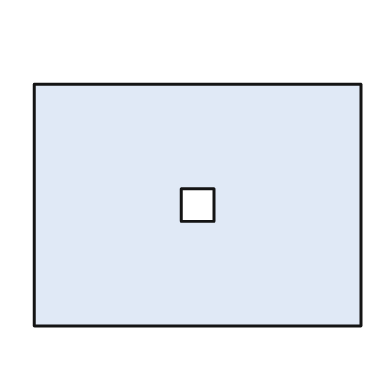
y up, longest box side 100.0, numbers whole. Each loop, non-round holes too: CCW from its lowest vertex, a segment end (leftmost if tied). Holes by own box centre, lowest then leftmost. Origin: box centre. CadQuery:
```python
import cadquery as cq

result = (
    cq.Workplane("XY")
    .moveTo(-50.0, -37.0)
    .lineTo(50.0, -37.0)
    .lineTo(50.0, 37.0)
    .lineTo(-50.0, 37.0)
    .close()
    .moveTo(-5.0, -5.0)
    .lineTo(5.0, -5.0)
    .lineTo(5.0, 5.0)
    .lineTo(-5.0, 5.0)
    .close()
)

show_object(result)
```